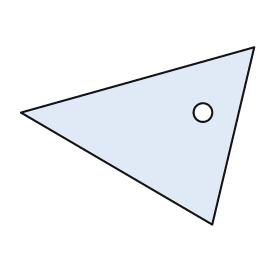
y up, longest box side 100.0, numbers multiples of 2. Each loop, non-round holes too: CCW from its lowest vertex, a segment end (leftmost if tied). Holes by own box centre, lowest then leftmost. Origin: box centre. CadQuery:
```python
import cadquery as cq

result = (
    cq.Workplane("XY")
    .moveTo(32.0, -38.0)
    .lineTo(50.0, 38.0)
    .lineTo(-50.0, 10.0)
    .close()
    .moveTo(28.0, 10.0)
    .circle(4.0)
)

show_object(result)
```